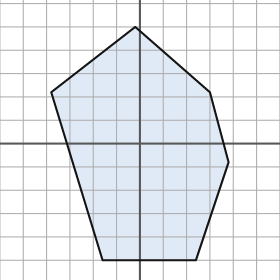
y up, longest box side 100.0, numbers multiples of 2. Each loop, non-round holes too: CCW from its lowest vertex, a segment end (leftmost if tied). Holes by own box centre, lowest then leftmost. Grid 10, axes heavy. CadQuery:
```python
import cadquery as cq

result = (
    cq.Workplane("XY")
    .moveTo(-16.0, -50.0)
    .lineTo(24.0, -50.0)
    .lineTo(38.0, -8.0)
    .lineTo(30.0, 22.0)
    .lineTo(-2.0, 50.0)
    .lineTo(-38.0, 22.0)
    .close()
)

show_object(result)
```